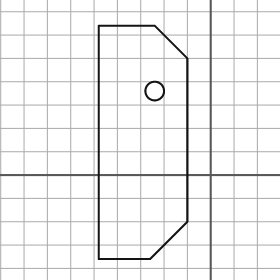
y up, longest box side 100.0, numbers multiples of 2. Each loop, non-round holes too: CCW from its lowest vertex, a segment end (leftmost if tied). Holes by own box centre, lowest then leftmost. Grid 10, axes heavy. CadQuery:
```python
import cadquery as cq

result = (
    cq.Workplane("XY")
    .moveTo(-48.0, -36.0)
    .lineTo(-26.0, -36.0)
    .lineTo(-10.0, -20.0)
    .lineTo(-10.0, 50.0)
    .lineTo(-24.0, 64.0)
    .lineTo(-48.0, 64.0)
    .close()
    .moveTo(-24.0, 36.0)
    .circle(4.0)
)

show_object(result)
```